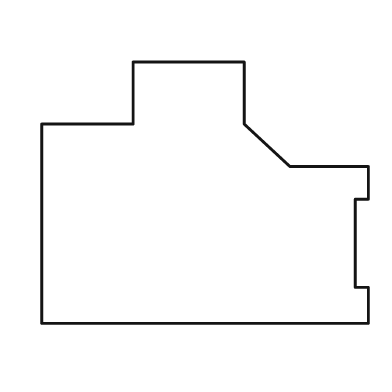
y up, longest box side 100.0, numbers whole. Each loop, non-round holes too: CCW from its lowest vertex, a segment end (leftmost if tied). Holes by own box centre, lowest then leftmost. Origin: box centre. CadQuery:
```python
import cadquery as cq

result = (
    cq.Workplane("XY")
    .moveTo(-50.0, -40.0)
    .lineTo(50.0, -40.0)
    .lineTo(50.0, -29.0)
    .lineTo(46.0, -29.0)
    .lineTo(46.0, -2.0)
    .lineTo(50.0, -2.0)
    .lineTo(50.0, 8.0)
    .lineTo(26.0, 8.0)
    .lineTo(12.0, 21.0)
    .lineTo(12.0, 40.0)
    .lineTo(-22.0, 40.0)
    .lineTo(-22.0, 21.0)
    .lineTo(-50.0, 21.0)
    .close()
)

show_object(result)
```